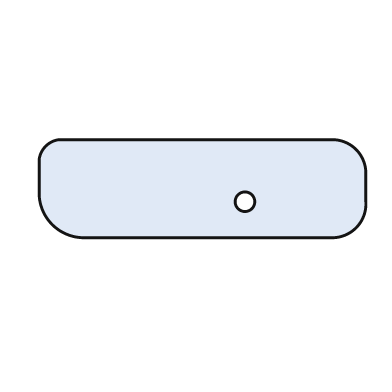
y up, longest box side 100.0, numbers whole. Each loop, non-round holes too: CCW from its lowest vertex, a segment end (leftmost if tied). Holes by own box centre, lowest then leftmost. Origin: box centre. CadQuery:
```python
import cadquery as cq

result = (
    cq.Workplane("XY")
    .moveTo(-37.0, -15.0)
    .lineTo(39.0, -15.0)
    .threePointArc((47.0, -12.0), (50.0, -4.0))
    .lineTo(50.0, 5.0)
    .threePointArc((47.0, 12.0), (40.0, 15.0))
    .lineTo(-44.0, 15.0)
    .threePointArc((-48.0, 13.0), (-50.0, 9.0))
    .lineTo(-50.0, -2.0)
    .threePointArc((-46.0, -11.0), (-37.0, -15.0))
    .close()
    .moveTo(13.0, -4.0)
    .circle(3.0)
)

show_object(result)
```